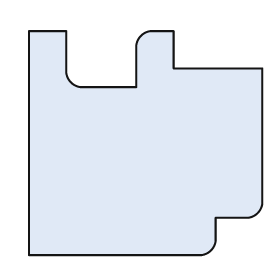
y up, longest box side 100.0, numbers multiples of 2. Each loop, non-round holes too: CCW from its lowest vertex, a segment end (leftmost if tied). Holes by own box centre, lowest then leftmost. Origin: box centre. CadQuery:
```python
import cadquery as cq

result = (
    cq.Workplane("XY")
    .moveTo(-50.0, -48.0)
    .lineTo(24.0, -48.0)
    .threePointArc((28.0, -46.0), (30.0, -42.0))
    .lineTo(30.0, -32.0)
    .lineTo(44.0, -32.0)
    .threePointArc((48.0, -30.0), (50.0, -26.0))
    .lineTo(50.0, 32.0)
    .lineTo(12.0, 32.0)
    .lineTo(12.0, 48.0)
    .lineTo(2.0, 48.0)
    .threePointArc((-2.0, 46.0), (-4.0, 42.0))
    .lineTo(-4.0, 24.0)
    .lineTo(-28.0, 24.0)
    .threePointArc((-32.0, 26.0), (-34.0, 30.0))
    .lineTo(-34.0, 48.0)
    .lineTo(-50.0, 48.0)
    .close()
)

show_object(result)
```